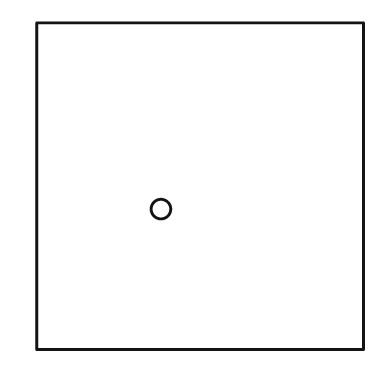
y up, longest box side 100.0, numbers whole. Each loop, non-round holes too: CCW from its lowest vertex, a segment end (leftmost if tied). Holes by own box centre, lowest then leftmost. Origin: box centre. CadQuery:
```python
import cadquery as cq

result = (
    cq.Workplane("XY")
    .moveTo(-50.0, -50.0)
    .lineTo(50.0, -50.0)
    .lineTo(50.0, 50.0)
    .lineTo(-50.0, 50.0)
    .close()
    .moveTo(-12.0, -7.0)
    .circle(3.0)
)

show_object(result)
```